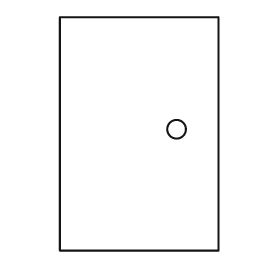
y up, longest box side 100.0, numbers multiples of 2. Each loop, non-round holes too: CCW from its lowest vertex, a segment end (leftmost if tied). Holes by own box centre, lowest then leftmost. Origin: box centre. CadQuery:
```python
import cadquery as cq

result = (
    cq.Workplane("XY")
    .moveTo(-34.0, -50.0)
    .lineTo(34.0, -50.0)
    .lineTo(34.0, 50.0)
    .lineTo(-34.0, 50.0)
    .close()
    .moveTo(16.0, 2.0)
    .circle(4.0)
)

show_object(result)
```